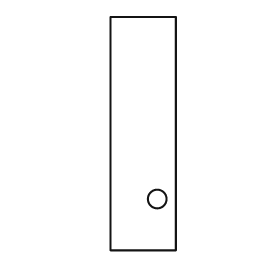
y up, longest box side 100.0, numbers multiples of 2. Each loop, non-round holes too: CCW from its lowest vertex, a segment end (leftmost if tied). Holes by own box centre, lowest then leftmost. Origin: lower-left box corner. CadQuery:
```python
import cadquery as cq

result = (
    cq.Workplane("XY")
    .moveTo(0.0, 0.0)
    .lineTo(28.0, 0.0)
    .lineTo(28.0, 100.0)
    .lineTo(0.0, 100.0)
    .close()
    .moveTo(20.0, 22.0)
    .circle(4.0)
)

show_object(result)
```